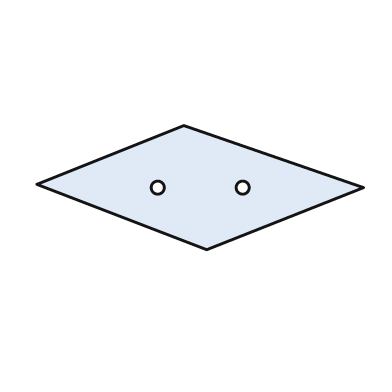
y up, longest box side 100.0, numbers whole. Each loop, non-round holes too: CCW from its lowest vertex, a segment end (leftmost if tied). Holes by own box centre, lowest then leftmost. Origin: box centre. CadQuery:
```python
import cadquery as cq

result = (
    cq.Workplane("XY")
    .moveTo(2.0, -19.0)
    .lineTo(50.0, 0.0)
    .lineTo(-5.0, 19.0)
    .lineTo(-50.0, 1.0)
    .close()
    .moveTo(-13.0, 0.0)
    .circle(2.0)
    .moveTo(13.0, 0.0)
    .circle(2.0)
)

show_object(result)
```